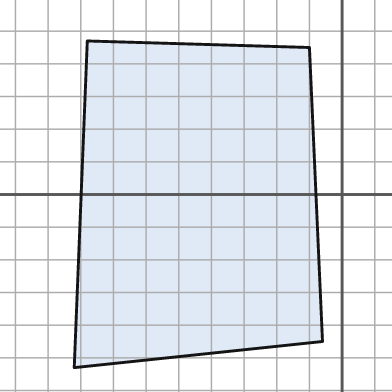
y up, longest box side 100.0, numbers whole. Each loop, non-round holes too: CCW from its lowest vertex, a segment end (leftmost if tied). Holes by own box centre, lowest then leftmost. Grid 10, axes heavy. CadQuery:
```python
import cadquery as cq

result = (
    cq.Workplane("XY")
    .moveTo(-82.0, -53.0)
    .lineTo(-6.0, -45.0)
    .lineTo(-10.0, 45.0)
    .lineTo(-78.0, 47.0)
    .close()
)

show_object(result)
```